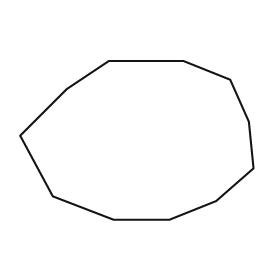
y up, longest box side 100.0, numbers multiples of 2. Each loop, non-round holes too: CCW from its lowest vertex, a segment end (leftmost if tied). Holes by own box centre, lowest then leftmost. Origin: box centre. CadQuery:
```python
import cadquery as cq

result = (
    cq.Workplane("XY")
    .moveTo(-10.0, -34.0)
    .lineTo(14.0, -34.0)
    .lineTo(34.0, -26.0)
    .lineTo(50.0, -12.0)
    .lineTo(48.0, 8.0)
    .lineTo(40.0, 26.0)
    .lineTo(20.0, 34.0)
    .lineTo(-12.0, 34.0)
    .lineTo(-30.0, 22.0)
    .lineTo(-50.0, 2.0)
    .lineTo(-36.0, -24.0)
    .close()
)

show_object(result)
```